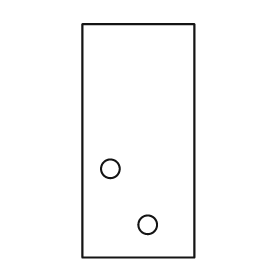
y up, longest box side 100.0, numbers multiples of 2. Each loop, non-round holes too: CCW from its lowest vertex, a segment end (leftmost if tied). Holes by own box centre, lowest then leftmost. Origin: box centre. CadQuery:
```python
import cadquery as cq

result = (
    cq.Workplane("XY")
    .moveTo(-24.0, -50.0)
    .lineTo(24.0, -50.0)
    .lineTo(24.0, 50.0)
    .lineTo(-24.0, 50.0)
    .close()
    .moveTo(4.0, -36.0)
    .circle(4.0)
    .moveTo(-12.0, -12.0)
    .circle(4.0)
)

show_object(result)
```